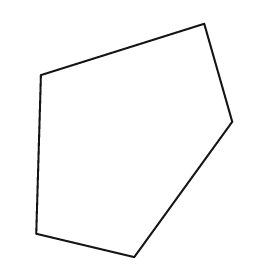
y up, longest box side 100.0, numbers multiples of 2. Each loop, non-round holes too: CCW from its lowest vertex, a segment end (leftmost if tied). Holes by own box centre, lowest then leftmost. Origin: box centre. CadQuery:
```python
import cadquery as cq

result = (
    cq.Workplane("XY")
    .moveTo(0.0, -50.0)
    .lineTo(42.0, 8.0)
    .lineTo(30.0, 50.0)
    .lineTo(-40.0, 28.0)
    .lineTo(-42.0, -40.0)
    .close()
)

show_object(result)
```